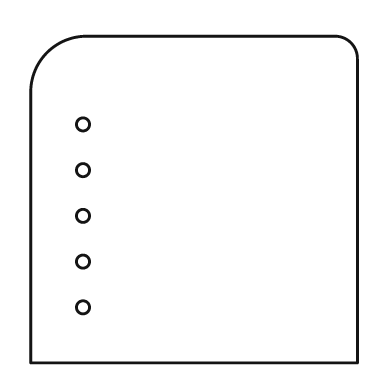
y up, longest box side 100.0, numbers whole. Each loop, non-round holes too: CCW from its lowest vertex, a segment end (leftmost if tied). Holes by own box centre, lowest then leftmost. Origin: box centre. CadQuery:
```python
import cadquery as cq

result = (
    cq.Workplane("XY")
    .moveTo(-50.0, -50.0)
    .lineTo(50.0, -50.0)
    .lineTo(50.0, 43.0)
    .threePointArc((48.0, 48.0), (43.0, 50.0))
    .lineTo(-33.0, 50.0)
    .threePointArc((-45.0, 45.0), (-50.0, 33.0))
    .close()
    .moveTo(-34.0, -33.0)
    .circle(2.0)
    .moveTo(-34.0, -19.0)
    .circle(2.0)
    .moveTo(-34.0, -5.0)
    .circle(2.0)
    .moveTo(-34.0, 9.0)
    .circle(2.0)
    .moveTo(-34.0, 23.0)
    .circle(2.0)
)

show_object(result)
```